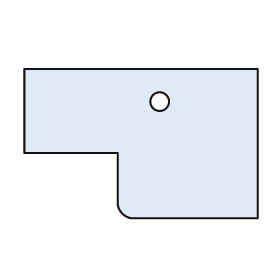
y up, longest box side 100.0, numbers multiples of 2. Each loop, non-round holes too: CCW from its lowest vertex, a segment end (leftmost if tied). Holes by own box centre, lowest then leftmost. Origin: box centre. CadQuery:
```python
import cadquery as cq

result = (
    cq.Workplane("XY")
    .moveTo(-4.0, -32.0)
    .lineTo(50.0, -32.0)
    .lineTo(50.0, 32.0)
    .lineTo(-50.0, 32.0)
    .lineTo(-50.0, -4.0)
    .lineTo(-10.0, -4.0)
    .lineTo(-10.0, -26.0)
    .threePointArc((-8.0, -30.0), (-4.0, -32.0))
    .close()
    .moveTo(8.0, 18.0)
    .circle(4.0)
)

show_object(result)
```